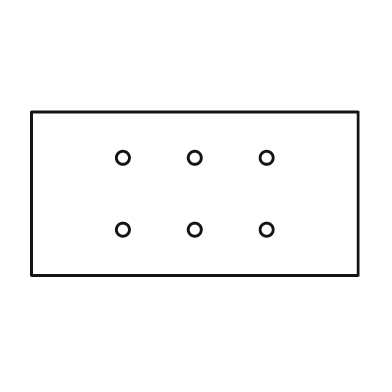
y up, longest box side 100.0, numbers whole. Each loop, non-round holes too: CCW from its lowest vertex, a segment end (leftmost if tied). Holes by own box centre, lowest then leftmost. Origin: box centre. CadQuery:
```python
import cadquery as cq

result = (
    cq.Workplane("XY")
    .moveTo(-50.0, -25.0)
    .lineTo(50.0, -25.0)
    .lineTo(50.0, 25.0)
    .lineTo(-50.0, 25.0)
    .close()
    .moveTo(-22.0, -11.0)
    .circle(2.0)
    .moveTo(0.0, -11.0)
    .circle(2.0)
    .moveTo(22.0, -11.0)
    .circle(2.0)
    .moveTo(-22.0, 11.0)
    .circle(2.0)
    .moveTo(0.0, 11.0)
    .circle(2.0)
    .moveTo(22.0, 11.0)
    .circle(2.0)
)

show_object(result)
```